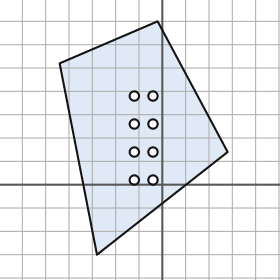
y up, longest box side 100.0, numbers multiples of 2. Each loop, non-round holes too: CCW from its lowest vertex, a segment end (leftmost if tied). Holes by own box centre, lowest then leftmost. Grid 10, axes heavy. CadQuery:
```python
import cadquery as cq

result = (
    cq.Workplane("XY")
    .moveTo(-28.0, -30.0)
    .lineTo(28.0, 14.0)
    .lineTo(-2.0, 70.0)
    .lineTo(-44.0, 52.0)
    .close()
    .moveTo(-12.0, 2.0)
    .circle(2.0)
    .moveTo(-4.0, 2.0)
    .circle(2.0)
    .moveTo(-12.0, 14.0)
    .circle(2.0)
    .moveTo(-4.0, 14.0)
    .circle(2.0)
    .moveTo(-12.0, 26.0)
    .circle(2.0)
    .moveTo(-4.0, 26.0)
    .circle(2.0)
    .moveTo(-12.0, 38.0)
    .circle(2.0)
    .moveTo(-4.0, 38.0)
    .circle(2.0)
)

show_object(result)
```